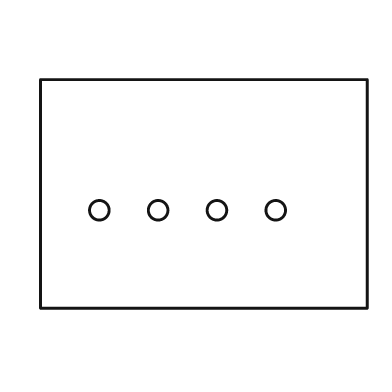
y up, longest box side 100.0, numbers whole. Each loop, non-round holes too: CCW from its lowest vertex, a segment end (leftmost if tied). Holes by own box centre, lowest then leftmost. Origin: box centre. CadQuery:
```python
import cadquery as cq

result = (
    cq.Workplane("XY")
    .moveTo(-50.0, -35.0)
    .lineTo(50.0, -35.0)
    .lineTo(50.0, 35.0)
    .lineTo(-50.0, 35.0)
    .close()
    .moveTo(-32.0, -5.0)
    .circle(3.0)
    .moveTo(-14.0, -5.0)
    .circle(3.0)
    .moveTo(4.0, -5.0)
    .circle(3.0)
    .moveTo(22.0, -5.0)
    .circle(3.0)
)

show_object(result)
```